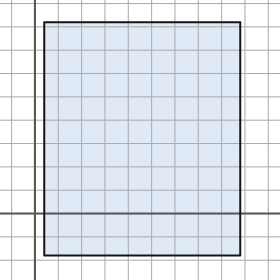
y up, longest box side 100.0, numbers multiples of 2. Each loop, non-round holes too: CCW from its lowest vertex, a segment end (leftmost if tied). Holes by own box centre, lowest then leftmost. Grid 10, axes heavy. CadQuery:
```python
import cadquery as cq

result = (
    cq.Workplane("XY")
    .moveTo(4.0, -18.0)
    .lineTo(88.0, -18.0)
    .lineTo(88.0, 82.0)
    .lineTo(4.0, 82.0)
    .close()
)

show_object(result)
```